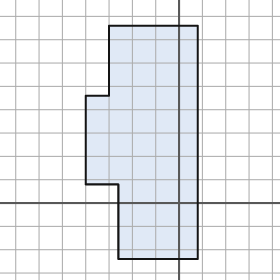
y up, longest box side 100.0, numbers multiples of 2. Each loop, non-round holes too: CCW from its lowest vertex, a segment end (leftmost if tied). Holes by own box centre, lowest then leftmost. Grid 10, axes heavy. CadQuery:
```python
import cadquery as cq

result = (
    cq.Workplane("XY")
    .moveTo(-26.0, -24.0)
    .lineTo(8.0, -24.0)
    .lineTo(8.0, 76.0)
    .lineTo(-30.0, 76.0)
    .lineTo(-30.0, 46.0)
    .lineTo(-40.0, 46.0)
    .lineTo(-40.0, 8.0)
    .lineTo(-26.0, 8.0)
    .close()
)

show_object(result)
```